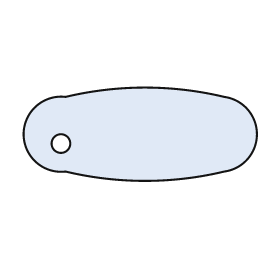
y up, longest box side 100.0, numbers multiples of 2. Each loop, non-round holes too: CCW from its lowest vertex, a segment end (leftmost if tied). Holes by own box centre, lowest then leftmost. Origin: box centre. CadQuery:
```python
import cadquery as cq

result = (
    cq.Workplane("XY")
    .moveTo(-32.0, -16.0)
    .threePointArc((2.0, -20.0), (36.0, -16.0))
    .threePointArc((50.0, 0.0), (36.0, 16.0))
    .threePointArc((2.0, 20.0), (-32.0, 16.0))
    .threePointArc((-50.0, 0.0), (-32.0, -16.0))
    .close()
    .moveTo(-34.0, -4.0)
    .circle(4.0)
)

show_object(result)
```